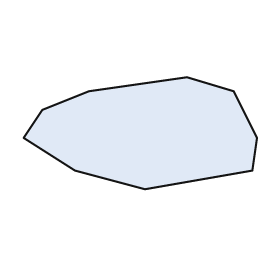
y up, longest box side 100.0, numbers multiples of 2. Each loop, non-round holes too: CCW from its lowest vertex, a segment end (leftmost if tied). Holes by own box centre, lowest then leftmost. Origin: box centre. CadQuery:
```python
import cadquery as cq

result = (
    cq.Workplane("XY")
    .moveTo(2.0, -24.0)
    .lineTo(48.0, -16.0)
    .lineTo(50.0, -2.0)
    .lineTo(40.0, 18.0)
    .lineTo(20.0, 24.0)
    .lineTo(-22.0, 18.0)
    .lineTo(-42.0, 10.0)
    .lineTo(-50.0, -2.0)
    .lineTo(-28.0, -16.0)
    .close()
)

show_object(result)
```